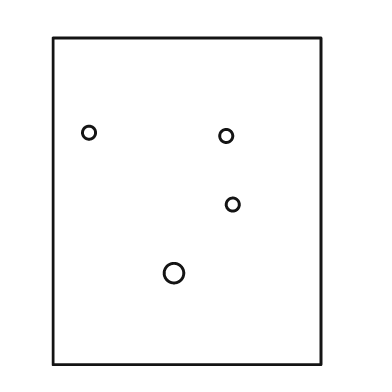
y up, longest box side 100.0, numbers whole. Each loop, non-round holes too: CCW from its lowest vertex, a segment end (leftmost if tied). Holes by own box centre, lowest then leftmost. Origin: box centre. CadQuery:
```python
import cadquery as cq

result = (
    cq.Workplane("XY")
    .moveTo(-41.0, -50.0)
    .lineTo(41.0, -50.0)
    .lineTo(41.0, 50.0)
    .lineTo(-41.0, 50.0)
    .close()
    .moveTo(-4.0, -22.0)
    .circle(3.0)
    .moveTo(14.0, -1.0)
    .circle(2.0)
    .moveTo(12.0, 20.0)
    .circle(2.0)
    .moveTo(-30.0, 21.0)
    .circle(2.0)
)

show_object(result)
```